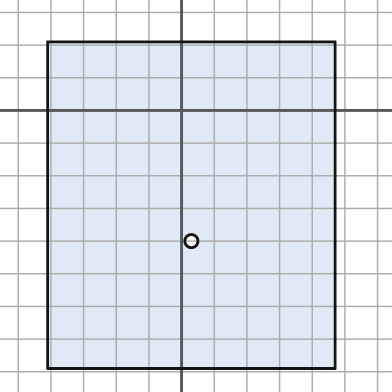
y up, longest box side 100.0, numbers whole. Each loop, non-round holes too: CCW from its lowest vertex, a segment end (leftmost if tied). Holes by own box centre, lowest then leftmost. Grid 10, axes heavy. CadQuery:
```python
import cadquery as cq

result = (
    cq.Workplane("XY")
    .moveTo(-41.0, -79.0)
    .lineTo(47.0, -79.0)
    .lineTo(47.0, 21.0)
    .lineTo(-41.0, 21.0)
    .close()
    .moveTo(3.0, -40.0)
    .circle(2.0)
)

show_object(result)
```